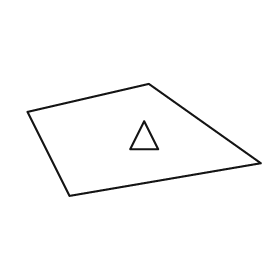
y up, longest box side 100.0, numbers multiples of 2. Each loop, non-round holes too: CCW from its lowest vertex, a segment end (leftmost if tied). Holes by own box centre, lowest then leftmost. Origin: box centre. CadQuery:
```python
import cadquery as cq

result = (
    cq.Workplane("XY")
    .moveTo(-32.0, -24.0)
    .lineTo(50.0, -10.0)
    .lineTo(2.0, 24.0)
    .lineTo(-50.0, 12.0)
    .close()
    .moveTo(-6.0, -4.0)
    .lineTo(6.0, -4.0)
    .lineTo(0.0, 8.0)
    .close()
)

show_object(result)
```